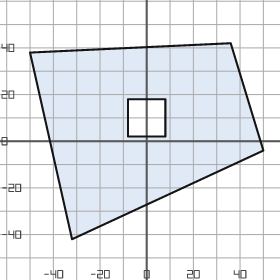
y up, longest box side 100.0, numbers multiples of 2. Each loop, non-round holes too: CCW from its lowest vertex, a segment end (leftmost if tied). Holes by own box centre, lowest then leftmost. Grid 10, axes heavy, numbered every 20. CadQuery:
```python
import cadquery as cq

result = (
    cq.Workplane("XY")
    .moveTo(-32.0, -42.0)
    .lineTo(50.0, -4.0)
    .lineTo(36.0, 42.0)
    .lineTo(-50.0, 38.0)
    .close()
    .moveTo(-8.0, 2.0)
    .lineTo(8.0, 2.0)
    .lineTo(8.0, 18.0)
    .lineTo(-8.0, 18.0)
    .close()
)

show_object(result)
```